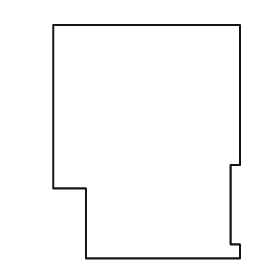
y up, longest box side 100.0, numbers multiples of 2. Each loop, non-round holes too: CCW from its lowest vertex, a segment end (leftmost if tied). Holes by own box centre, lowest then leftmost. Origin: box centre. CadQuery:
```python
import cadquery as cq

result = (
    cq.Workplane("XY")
    .moveTo(-26.0, -50.0)
    .lineTo(40.0, -50.0)
    .lineTo(40.0, -44.0)
    .lineTo(36.0, -44.0)
    .lineTo(36.0, -10.0)
    .lineTo(40.0, -10.0)
    .lineTo(40.0, 50.0)
    .lineTo(-40.0, 50.0)
    .lineTo(-40.0, -20.0)
    .lineTo(-26.0, -20.0)
    .close()
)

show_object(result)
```